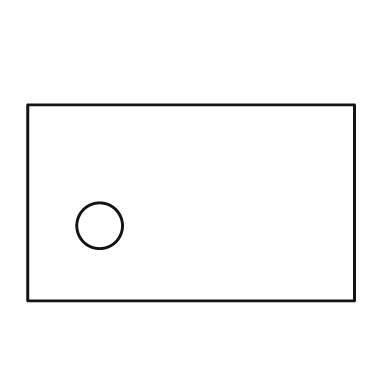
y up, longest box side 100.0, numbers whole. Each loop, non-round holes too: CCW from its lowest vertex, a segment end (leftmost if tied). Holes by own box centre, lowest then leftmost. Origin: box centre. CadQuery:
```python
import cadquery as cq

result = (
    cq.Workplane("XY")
    .moveTo(-50.0, -30.0)
    .lineTo(50.0, -30.0)
    .lineTo(50.0, 30.0)
    .lineTo(-50.0, 30.0)
    .close()
    .moveTo(-28.0, -7.0)
    .circle(7.0)
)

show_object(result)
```